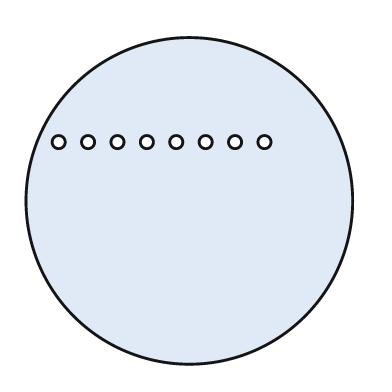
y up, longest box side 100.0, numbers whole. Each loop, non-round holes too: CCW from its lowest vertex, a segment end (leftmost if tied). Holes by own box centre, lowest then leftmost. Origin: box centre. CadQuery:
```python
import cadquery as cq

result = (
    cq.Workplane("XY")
    .moveTo(0.0, 0.0)
    .circle(50.0)
    .moveTo(-40.0, 18.0)
    .circle(2.0)
    .moveTo(-31.0, 18.0)
    .circle(2.0)
    .moveTo(-22.0, 18.0)
    .circle(2.0)
    .moveTo(-13.0, 18.0)
    .circle(2.0)
    .moveTo(-4.0, 18.0)
    .circle(2.0)
    .moveTo(5.0, 18.0)
    .circle(2.0)
    .moveTo(14.0, 18.0)
    .circle(2.0)
    .moveTo(23.0, 18.0)
    .circle(2.0)
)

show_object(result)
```